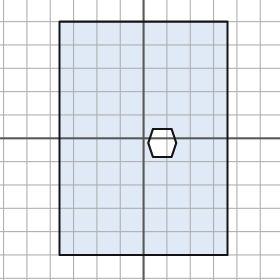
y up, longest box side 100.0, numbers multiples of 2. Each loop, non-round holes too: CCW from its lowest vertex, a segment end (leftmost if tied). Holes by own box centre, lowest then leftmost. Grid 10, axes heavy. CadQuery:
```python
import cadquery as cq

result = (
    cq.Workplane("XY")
    .moveTo(-36.0, -50.0)
    .lineTo(36.0, -50.0)
    .lineTo(36.0, 50.0)
    .lineTo(-36.0, 50.0)
    .close()
    .moveTo(4.0, -8.0)
    .lineTo(12.0, -8.0)
    .lineTo(14.0, -2.0)
    .lineTo(12.0, 4.0)
    .lineTo(4.0, 4.0)
    .lineTo(2.0, -2.0)
    .close()
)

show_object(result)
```